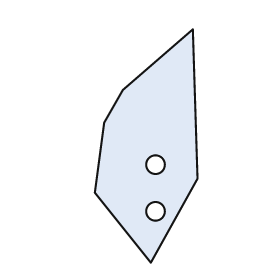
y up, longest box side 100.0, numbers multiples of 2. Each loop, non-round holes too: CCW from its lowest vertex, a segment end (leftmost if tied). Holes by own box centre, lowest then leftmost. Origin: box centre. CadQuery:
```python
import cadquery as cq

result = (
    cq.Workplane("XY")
    .moveTo(2.0, -50.0)
    .lineTo(22.0, -14.0)
    .lineTo(20.0, 50.0)
    .lineTo(-10.0, 24.0)
    .lineTo(-18.0, 10.0)
    .lineTo(-22.0, -20.0)
    .close()
    .moveTo(4.0, -28.0)
    .circle(4.0)
    .moveTo(4.0, -8.0)
    .circle(4.0)
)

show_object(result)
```